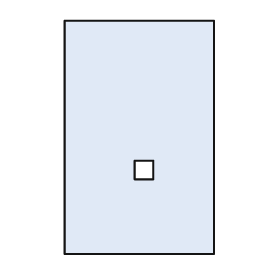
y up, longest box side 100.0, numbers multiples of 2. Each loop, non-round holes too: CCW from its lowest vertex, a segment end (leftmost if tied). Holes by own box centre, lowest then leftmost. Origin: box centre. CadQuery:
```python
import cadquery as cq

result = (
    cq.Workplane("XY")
    .moveTo(-32.0, -50.0)
    .lineTo(32.0, -50.0)
    .lineTo(32.0, 50.0)
    .lineTo(-32.0, 50.0)
    .close()
    .moveTo(-2.0, -18.0)
    .lineTo(6.0, -18.0)
    .lineTo(6.0, -10.0)
    .lineTo(-2.0, -10.0)
    .close()
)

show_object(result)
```